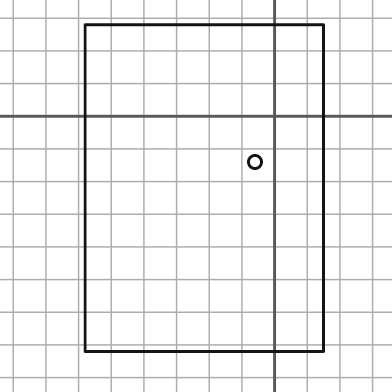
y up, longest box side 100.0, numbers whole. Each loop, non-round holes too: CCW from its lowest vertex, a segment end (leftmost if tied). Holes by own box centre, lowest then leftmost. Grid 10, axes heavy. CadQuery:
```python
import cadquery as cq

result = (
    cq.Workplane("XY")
    .moveTo(-58.0, -72.0)
    .lineTo(15.0, -72.0)
    .lineTo(15.0, 28.0)
    .lineTo(-58.0, 28.0)
    .close()
    .moveTo(-6.0, -14.0)
    .circle(2.0)
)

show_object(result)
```